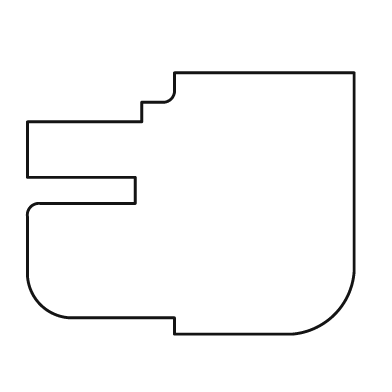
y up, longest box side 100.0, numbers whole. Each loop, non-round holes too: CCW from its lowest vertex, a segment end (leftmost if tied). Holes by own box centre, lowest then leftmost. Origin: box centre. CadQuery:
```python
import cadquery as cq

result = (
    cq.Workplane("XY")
    .moveTo(-5.0, -40.0)
    .lineTo(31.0, -40.0)
    .threePointArc((44.0, -34.0), (50.0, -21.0))
    .lineTo(50.0, 40.0)
    .lineTo(-5.0, 40.0)
    .lineTo(-5.0, 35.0)
    .threePointArc((-6.0, 32.0), (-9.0, 31.0))
    .lineTo(-15.0, 31.0)
    .lineTo(-15.0, 25.0)
    .lineTo(-50.0, 25.0)
    .lineTo(-50.0, 8.0)
    .lineTo(-17.0, 8.0)
    .lineTo(-17.0, 0.0)
    .lineTo(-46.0, 0.0)
    .threePointArc((-49.0, -1.0), (-50.0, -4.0))
    .lineTo(-50.0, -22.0)
    .threePointArc((-46.0, -31.0), (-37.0, -35.0))
    .lineTo(-5.0, -35.0)
    .close()
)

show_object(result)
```